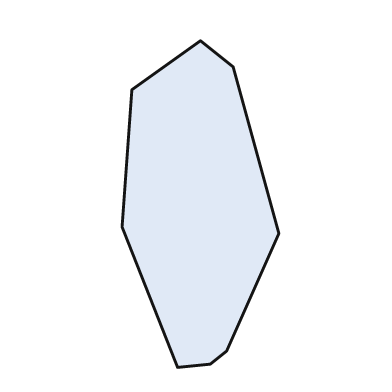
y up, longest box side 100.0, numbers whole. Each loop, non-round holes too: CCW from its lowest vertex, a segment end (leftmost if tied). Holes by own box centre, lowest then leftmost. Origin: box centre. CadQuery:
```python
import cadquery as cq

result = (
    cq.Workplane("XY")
    .moveTo(-7.0, -50.0)
    .lineTo(3.0, -49.0)
    .lineTo(8.0, -45.0)
    .lineTo(24.0, -9.0)
    .lineTo(10.0, 42.0)
    .lineTo(0.0, 50.0)
    .lineTo(-21.0, 35.0)
    .lineTo(-24.0, -7.0)
    .close()
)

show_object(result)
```